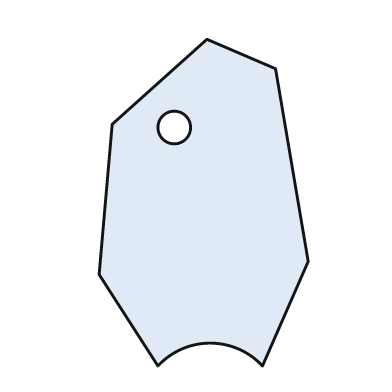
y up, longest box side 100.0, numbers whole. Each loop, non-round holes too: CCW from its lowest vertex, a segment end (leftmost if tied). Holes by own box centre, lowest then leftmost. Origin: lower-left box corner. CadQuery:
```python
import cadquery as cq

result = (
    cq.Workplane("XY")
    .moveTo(18.0, 0.0)
    .threePointArc((34.0, 7.0), (50.0, 0.0))
    .lineTo(64.0, 32.0)
    .lineTo(54.0, 91.0)
    .lineTo(33.0, 100.0)
    .lineTo(4.0, 74.0)
    .lineTo(0.0, 28.0)
    .close()
    .moveTo(23.0, 73.0)
    .circle(5.0)
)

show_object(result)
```